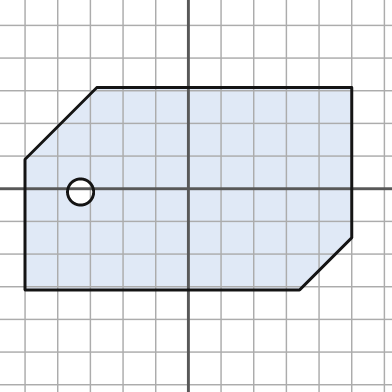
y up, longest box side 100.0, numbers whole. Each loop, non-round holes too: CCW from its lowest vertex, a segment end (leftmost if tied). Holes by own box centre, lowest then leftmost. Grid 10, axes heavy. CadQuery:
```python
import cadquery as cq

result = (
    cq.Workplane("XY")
    .moveTo(-50.0, -31.0)
    .lineTo(34.0, -31.0)
    .lineTo(50.0, -15.0)
    .lineTo(50.0, 31.0)
    .lineTo(-28.0, 31.0)
    .lineTo(-50.0, 9.0)
    .close()
    .moveTo(-33.0, -1.0)
    .circle(4.0)
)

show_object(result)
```